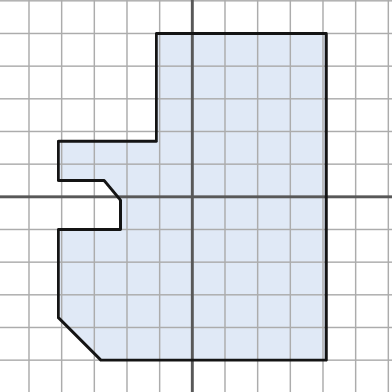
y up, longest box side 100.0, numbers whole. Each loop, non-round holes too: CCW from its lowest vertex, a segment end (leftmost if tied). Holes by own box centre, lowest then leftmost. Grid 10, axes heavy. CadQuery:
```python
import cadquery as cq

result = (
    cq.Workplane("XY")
    .moveTo(-28.0, -50.0)
    .lineTo(41.0, -50.0)
    .lineTo(41.0, 50.0)
    .lineTo(-11.0, 50.0)
    .lineTo(-11.0, 17.0)
    .lineTo(-41.0, 17.0)
    .lineTo(-41.0, 5.0)
    .lineTo(-27.0, 5.0)
    .lineTo(-22.0, -1.0)
    .lineTo(-22.0, -10.0)
    .lineTo(-41.0, -10.0)
    .lineTo(-41.0, -37.0)
    .close()
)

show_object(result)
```